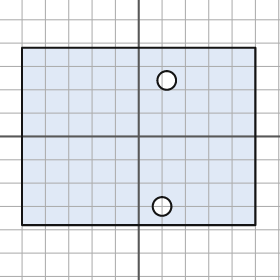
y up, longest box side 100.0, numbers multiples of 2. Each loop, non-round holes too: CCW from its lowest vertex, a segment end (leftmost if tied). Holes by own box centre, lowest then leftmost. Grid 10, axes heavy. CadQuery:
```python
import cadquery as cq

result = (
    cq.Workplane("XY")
    .moveTo(-50.0, -38.0)
    .lineTo(50.0, -38.0)
    .lineTo(50.0, 38.0)
    .lineTo(-50.0, 38.0)
    .close()
    .moveTo(10.0, -30.0)
    .circle(4.0)
    .moveTo(12.0, 24.0)
    .circle(4.0)
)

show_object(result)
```